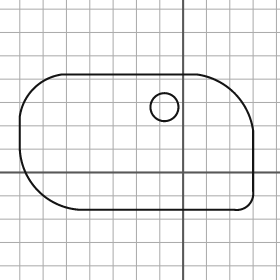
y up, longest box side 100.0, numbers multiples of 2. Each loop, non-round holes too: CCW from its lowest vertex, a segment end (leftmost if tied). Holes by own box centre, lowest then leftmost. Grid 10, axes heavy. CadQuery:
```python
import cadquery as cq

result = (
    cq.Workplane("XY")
    .moveTo(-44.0, -16.0)
    .lineTo(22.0, -16.0)
    .threePointArc((28.0, -14.0), (30.0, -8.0))
    .lineTo(30.0, 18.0)
    .threePointArc((22.0, 34.0), (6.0, 42.0))
    .lineTo(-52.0, 42.0)
    .threePointArc((-64.0, 36.0), (-70.0, 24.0))
    .lineTo(-70.0, 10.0)
    .threePointArc((-62.0, -8.0), (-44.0, -16.0))
    .close()
    .moveTo(-8.0, 28.0)
    .circle(6.0)
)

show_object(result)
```